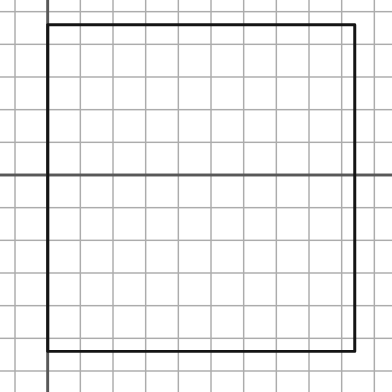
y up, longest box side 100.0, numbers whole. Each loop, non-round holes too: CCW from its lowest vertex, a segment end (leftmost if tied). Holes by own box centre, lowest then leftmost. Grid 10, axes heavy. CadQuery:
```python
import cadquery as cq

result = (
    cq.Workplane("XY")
    .moveTo(0.0, -54.0)
    .lineTo(94.0, -54.0)
    .lineTo(94.0, 46.0)
    .lineTo(0.0, 46.0)
    .close()
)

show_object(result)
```